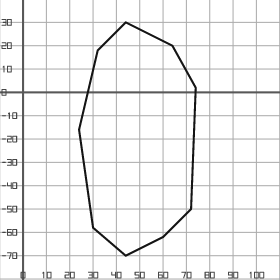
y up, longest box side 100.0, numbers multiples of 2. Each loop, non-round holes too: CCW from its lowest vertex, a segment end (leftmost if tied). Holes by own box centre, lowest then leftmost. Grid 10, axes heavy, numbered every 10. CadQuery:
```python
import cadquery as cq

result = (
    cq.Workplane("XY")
    .moveTo(44.0, -70.0)
    .lineTo(60.0, -62.0)
    .lineTo(72.0, -50.0)
    .lineTo(74.0, 2.0)
    .lineTo(64.0, 20.0)
    .lineTo(44.0, 30.0)
    .lineTo(32.0, 18.0)
    .lineTo(24.0, -16.0)
    .lineTo(30.0, -58.0)
    .close()
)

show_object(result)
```